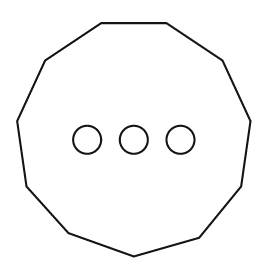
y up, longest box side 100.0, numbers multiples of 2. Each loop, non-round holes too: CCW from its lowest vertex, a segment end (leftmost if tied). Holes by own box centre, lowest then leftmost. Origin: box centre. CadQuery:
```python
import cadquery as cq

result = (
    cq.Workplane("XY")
    .moveTo(0.0, -50.0)
    .lineTo(28.0, -42.0)
    .lineTo(46.0, -20.0)
    .lineTo(50.0, 8.0)
    .lineTo(38.0, 34.0)
    .lineTo(14.0, 50.0)
    .lineTo(-14.0, 50.0)
    .lineTo(-38.0, 34.0)
    .lineTo(-50.0, 8.0)
    .lineTo(-46.0, -20.0)
    .lineTo(-28.0, -40.0)
    .close()
    .moveTo(-20.0, 0.0)
    .circle(6.0)
    .moveTo(0.0, 0.0)
    .circle(6.0)
    .moveTo(20.0, 0.0)
    .circle(6.0)
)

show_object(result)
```